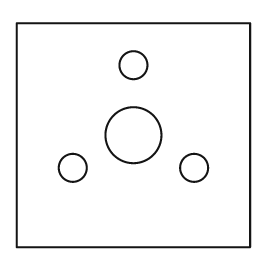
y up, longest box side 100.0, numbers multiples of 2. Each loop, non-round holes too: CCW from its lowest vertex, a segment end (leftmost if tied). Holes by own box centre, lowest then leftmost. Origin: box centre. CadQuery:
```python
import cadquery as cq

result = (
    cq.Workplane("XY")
    .moveTo(-50.0, -48.0)
    .lineTo(50.0, -48.0)
    .lineTo(50.0, 48.0)
    .lineTo(-50.0, 48.0)
    .close()
    .moveTo(-26.0, -14.0)
    .circle(6.0)
    .moveTo(26.0, -14.0)
    .circle(6.0)
    .moveTo(0.0, 0.0)
    .circle(12.0)
    .moveTo(0.0, 30.0)
    .circle(6.0)
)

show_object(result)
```